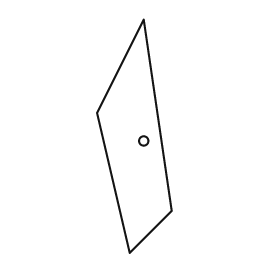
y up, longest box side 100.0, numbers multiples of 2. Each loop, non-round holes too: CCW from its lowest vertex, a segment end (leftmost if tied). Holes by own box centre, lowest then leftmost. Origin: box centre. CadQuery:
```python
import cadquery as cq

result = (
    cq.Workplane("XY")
    .moveTo(-2.0, -50.0)
    .lineTo(16.0, -32.0)
    .lineTo(4.0, 50.0)
    .lineTo(-16.0, 10.0)
    .close()
    .moveTo(4.0, -2.0)
    .circle(2.0)
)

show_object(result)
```